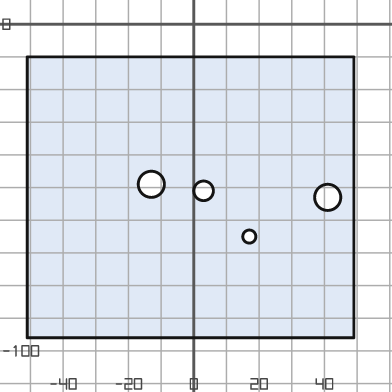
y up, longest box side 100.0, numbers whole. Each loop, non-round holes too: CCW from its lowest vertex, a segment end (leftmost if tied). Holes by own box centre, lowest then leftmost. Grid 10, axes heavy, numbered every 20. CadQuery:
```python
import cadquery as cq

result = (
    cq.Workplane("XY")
    .moveTo(-51.0, -96.0)
    .lineTo(49.0, -96.0)
    .lineTo(49.0, -10.0)
    .lineTo(-51.0, -10.0)
    .close()
    .moveTo(17.0, -65.0)
    .circle(2.0)
    .moveTo(41.0, -53.0)
    .circle(4.0)
    .moveTo(3.0, -51.0)
    .circle(3.0)
    .moveTo(-13.0, -49.0)
    .circle(4.0)
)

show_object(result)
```